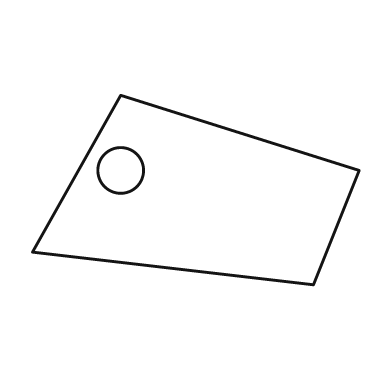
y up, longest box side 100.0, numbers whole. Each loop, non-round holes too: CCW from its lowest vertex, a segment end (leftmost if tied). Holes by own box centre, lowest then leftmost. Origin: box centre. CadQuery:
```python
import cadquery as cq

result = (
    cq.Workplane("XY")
    .moveTo(36.0, -29.0)
    .lineTo(50.0, 6.0)
    .lineTo(-23.0, 29.0)
    .lineTo(-50.0, -19.0)
    .close()
    .moveTo(-23.0, 6.0)
    .circle(7.0)
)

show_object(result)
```